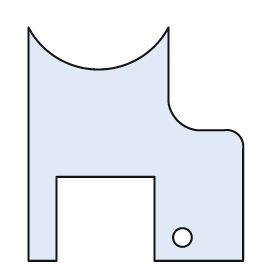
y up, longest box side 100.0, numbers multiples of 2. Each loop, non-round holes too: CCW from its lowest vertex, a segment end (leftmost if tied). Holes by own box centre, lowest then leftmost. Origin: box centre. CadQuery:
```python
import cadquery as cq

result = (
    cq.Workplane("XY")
    .moveTo(-46.0, -50.0)
    .lineTo(-34.0, -50.0)
    .lineTo(-34.0, -14.0)
    .lineTo(8.0, -14.0)
    .lineTo(8.0, -50.0)
    .lineTo(46.0, -50.0)
    .lineTo(46.0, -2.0)
    .threePointArc((44.0, 4.0), (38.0, 6.0))
    .lineTo(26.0, 6.0)
    .threePointArc((18.0, 10.0), (14.0, 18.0))
    .lineTo(14.0, 50.0)
    .threePointArc((-16.0, 32.0), (-46.0, 50.0))
    .close()
    .moveTo(20.0, -40.0)
    .circle(4.0)
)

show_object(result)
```